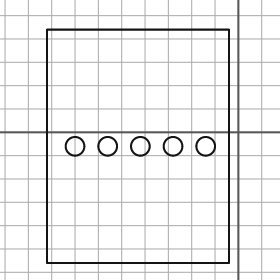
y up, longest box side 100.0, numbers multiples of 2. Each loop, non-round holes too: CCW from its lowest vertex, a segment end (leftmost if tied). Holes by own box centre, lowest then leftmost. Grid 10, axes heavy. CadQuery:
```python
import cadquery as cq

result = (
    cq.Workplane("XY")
    .moveTo(-82.0, -56.0)
    .lineTo(-4.0, -56.0)
    .lineTo(-4.0, 44.0)
    .lineTo(-82.0, 44.0)
    .close()
    .moveTo(-70.0, -6.0)
    .circle(4.0)
    .moveTo(-56.0, -6.0)
    .circle(4.0)
    .moveTo(-42.0, -6.0)
    .circle(4.0)
    .moveTo(-28.0, -6.0)
    .circle(4.0)
    .moveTo(-14.0, -6.0)
    .circle(4.0)
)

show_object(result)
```